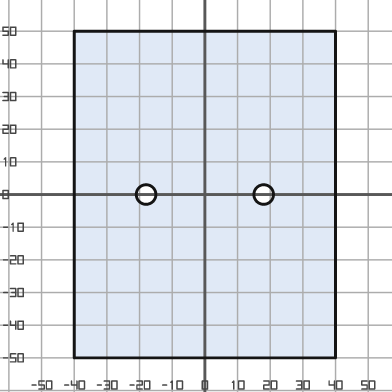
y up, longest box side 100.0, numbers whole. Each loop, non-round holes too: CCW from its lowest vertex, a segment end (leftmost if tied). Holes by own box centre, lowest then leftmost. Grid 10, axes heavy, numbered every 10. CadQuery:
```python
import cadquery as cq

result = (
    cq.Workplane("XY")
    .moveTo(-40.0, -50.0)
    .lineTo(40.0, -50.0)
    .lineTo(40.0, 50.0)
    .lineTo(-40.0, 50.0)
    .close()
    .moveTo(-18.0, 0.0)
    .circle(3.0)
    .moveTo(18.0, 0.0)
    .circle(3.0)
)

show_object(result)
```